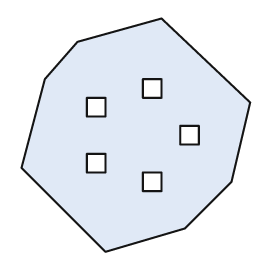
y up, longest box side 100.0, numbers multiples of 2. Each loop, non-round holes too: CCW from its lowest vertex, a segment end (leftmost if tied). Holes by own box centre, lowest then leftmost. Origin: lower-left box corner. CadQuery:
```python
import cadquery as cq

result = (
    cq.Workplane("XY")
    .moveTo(36.0, 0.0)
    .lineTo(70.0, 10.0)
    .lineTo(90.0, 30.0)
    .lineTo(98.0, 64.0)
    .lineTo(60.0, 100.0)
    .lineTo(24.0, 90.0)
    .lineTo(10.0, 74.0)
    .lineTo(0.0, 36.0)
    .close()
    .moveTo(52.0, 26.0)
    .lineTo(60.0, 26.0)
    .lineTo(60.0, 34.0)
    .lineTo(52.0, 34.0)
    .close()
    .moveTo(28.0, 34.0)
    .lineTo(36.0, 34.0)
    .lineTo(36.0, 42.0)
    .lineTo(28.0, 42.0)
    .close()
    .moveTo(68.0, 46.0)
    .lineTo(76.0, 46.0)
    .lineTo(76.0, 54.0)
    .lineTo(68.0, 54.0)
    .close()
    .moveTo(28.0, 58.0)
    .lineTo(36.0, 58.0)
    .lineTo(36.0, 66.0)
    .lineTo(28.0, 66.0)
    .close()
    .moveTo(52.0, 66.0)
    .lineTo(60.0, 66.0)
    .lineTo(60.0, 74.0)
    .lineTo(52.0, 74.0)
    .close()
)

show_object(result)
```